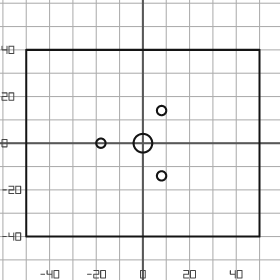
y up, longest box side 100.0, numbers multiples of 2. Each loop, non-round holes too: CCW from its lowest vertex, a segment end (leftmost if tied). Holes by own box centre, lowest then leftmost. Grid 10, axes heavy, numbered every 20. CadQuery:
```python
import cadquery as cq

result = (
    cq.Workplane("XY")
    .moveTo(-50.0, -40.0)
    .lineTo(50.0, -40.0)
    .lineTo(50.0, 40.0)
    .lineTo(-50.0, 40.0)
    .close()
    .moveTo(8.0, -14.0)
    .circle(2.0)
    .moveTo(-18.0, 0.0)
    .circle(2.0)
    .moveTo(0.0, 0.0)
    .circle(4.0)
    .moveTo(8.0, 14.0)
    .circle(2.0)
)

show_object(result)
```